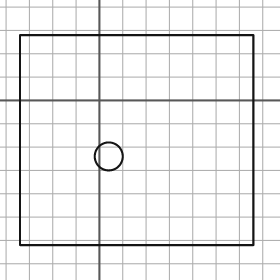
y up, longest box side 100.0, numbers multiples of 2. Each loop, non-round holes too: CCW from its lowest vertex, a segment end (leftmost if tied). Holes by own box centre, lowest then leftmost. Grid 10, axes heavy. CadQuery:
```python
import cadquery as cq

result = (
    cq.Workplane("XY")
    .moveTo(-34.0, -62.0)
    .lineTo(66.0, -62.0)
    .lineTo(66.0, 28.0)
    .lineTo(-34.0, 28.0)
    .close()
    .moveTo(4.0, -24.0)
    .circle(6.0)
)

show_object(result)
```